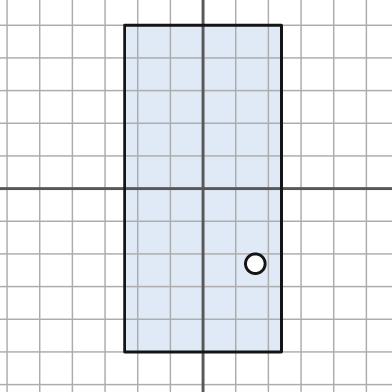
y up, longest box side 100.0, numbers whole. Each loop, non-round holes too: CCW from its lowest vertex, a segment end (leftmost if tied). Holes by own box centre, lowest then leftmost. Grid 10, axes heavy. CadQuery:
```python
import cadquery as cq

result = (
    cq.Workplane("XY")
    .moveTo(-24.0, -50.0)
    .lineTo(24.0, -50.0)
    .lineTo(24.0, 50.0)
    .lineTo(-24.0, 50.0)
    .close()
    .moveTo(16.0, -23.0)
    .circle(3.0)
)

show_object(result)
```